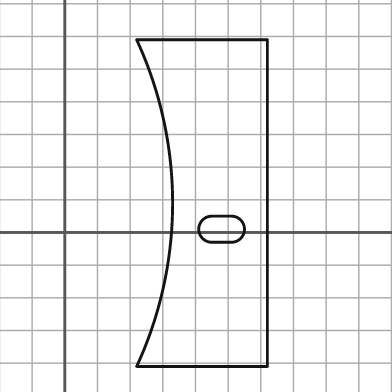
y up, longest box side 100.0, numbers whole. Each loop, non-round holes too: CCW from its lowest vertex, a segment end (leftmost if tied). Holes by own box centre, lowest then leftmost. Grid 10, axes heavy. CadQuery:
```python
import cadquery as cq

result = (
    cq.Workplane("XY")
    .moveTo(22.0, -41.0)
    .lineTo(62.0, -41.0)
    .lineTo(62.0, 59.0)
    .lineTo(22.0, 59.0)
    .threePointArc((33.0, 9.0), (22.0, -41.0))
    .close()
    .moveTo(45.0, -3.0)
    .lineTo(51.0, -3.0)
    .threePointArc((55.0, 1.0), (51.0, 5.0))
    .lineTo(45.0, 5.0)
    .threePointArc((41.0, 1.0), (45.0, -3.0))
    .close()
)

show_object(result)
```